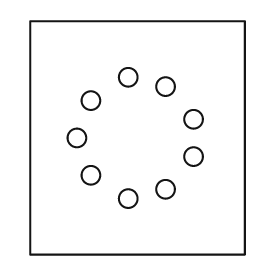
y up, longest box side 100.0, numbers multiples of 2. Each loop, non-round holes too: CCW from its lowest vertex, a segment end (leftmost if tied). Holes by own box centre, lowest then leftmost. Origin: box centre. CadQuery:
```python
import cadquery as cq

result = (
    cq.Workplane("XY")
    .moveTo(-46.0, -50.0)
    .lineTo(46.0, -50.0)
    .lineTo(46.0, 50.0)
    .lineTo(-46.0, 50.0)
    .close()
    .moveTo(-4.0, -26.0)
    .circle(4.0)
    .moveTo(12.0, -22.0)
    .circle(4.0)
    .moveTo(-20.0, -16.0)
    .circle(4.0)
    .moveTo(24.0, -8.0)
    .circle(4.0)
    .moveTo(-26.0, 0.0)
    .circle(4.0)
    .moveTo(24.0, 8.0)
    .circle(4.0)
    .moveTo(-20.0, 16.0)
    .circle(4.0)
    .moveTo(12.0, 22.0)
    .circle(4.0)
    .moveTo(-4.0, 26.0)
    .circle(4.0)
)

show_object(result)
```